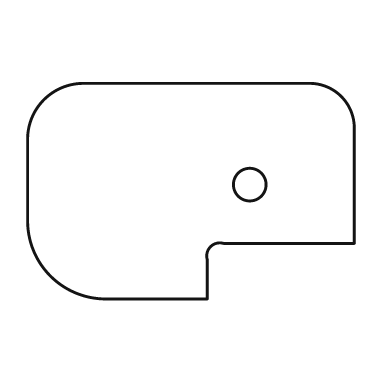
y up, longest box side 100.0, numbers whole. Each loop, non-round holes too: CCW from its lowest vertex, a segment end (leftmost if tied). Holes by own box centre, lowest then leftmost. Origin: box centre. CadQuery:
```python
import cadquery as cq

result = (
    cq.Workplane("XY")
    .moveTo(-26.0, -33.0)
    .lineTo(5.0, -33.0)
    .lineTo(5.0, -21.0)
    .threePointArc((6.0, -17.0), (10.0, -16.0))
    .lineTo(50.0, -16.0)
    .lineTo(50.0, 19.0)
    .threePointArc((46.0, 29.0), (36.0, 33.0))
    .lineTo(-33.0, 33.0)
    .threePointArc((-45.0, 28.0), (-50.0, 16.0))
    .lineTo(-50.0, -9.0)
    .threePointArc((-43.0, -26.0), (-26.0, -33.0))
    .close()
    .moveTo(18.0, 2.0)
    .circle(5.0)
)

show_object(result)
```